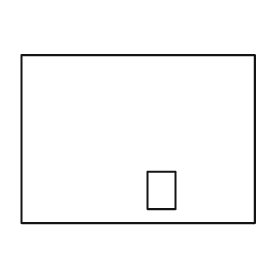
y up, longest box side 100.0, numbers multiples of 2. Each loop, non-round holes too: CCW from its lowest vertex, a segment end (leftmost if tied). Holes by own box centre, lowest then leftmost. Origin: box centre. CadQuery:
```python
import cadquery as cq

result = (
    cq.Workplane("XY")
    .moveTo(-50.0, -36.0)
    .lineTo(50.0, -36.0)
    .lineTo(50.0, 36.0)
    .lineTo(-50.0, 36.0)
    .close()
    .moveTo(4.0, -30.0)
    .lineTo(16.0, -30.0)
    .lineTo(16.0, -14.0)
    .lineTo(4.0, -14.0)
    .close()
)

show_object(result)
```